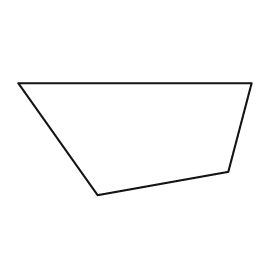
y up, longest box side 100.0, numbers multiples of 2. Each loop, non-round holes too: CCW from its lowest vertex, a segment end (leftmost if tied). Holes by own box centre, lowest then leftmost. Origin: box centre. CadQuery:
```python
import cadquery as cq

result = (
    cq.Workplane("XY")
    .moveTo(-16.0, -24.0)
    .lineTo(40.0, -14.0)
    .lineTo(50.0, 24.0)
    .lineTo(-50.0, 24.0)
    .close()
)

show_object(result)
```